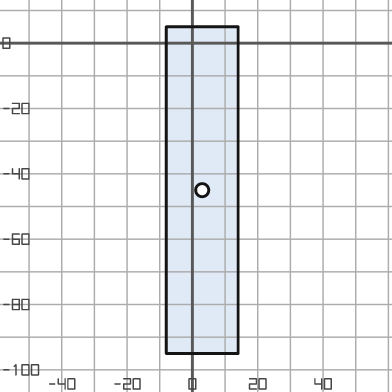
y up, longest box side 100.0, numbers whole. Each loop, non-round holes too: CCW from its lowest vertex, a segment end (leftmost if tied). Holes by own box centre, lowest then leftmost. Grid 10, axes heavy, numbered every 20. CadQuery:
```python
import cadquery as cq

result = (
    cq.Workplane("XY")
    .moveTo(-8.0, -95.0)
    .lineTo(14.0, -95.0)
    .lineTo(14.0, 5.0)
    .lineTo(-8.0, 5.0)
    .close()
    .moveTo(3.0, -45.0)
    .circle(2.0)
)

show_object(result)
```